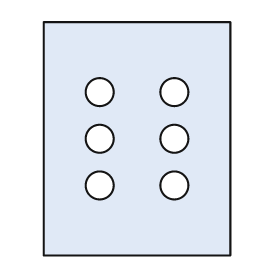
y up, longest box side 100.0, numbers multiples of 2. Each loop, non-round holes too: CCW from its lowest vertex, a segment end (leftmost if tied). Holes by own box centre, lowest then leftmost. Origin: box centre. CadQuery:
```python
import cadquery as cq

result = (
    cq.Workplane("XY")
    .moveTo(-40.0, -50.0)
    .lineTo(40.0, -50.0)
    .lineTo(40.0, 50.0)
    .lineTo(-40.0, 50.0)
    .close()
    .moveTo(-16.0, -20.0)
    .circle(6.0)
    .moveTo(16.0, -20.0)
    .circle(6.0)
    .moveTo(-16.0, 0.0)
    .circle(6.0)
    .moveTo(16.0, 0.0)
    .circle(6.0)
    .moveTo(-16.0, 20.0)
    .circle(6.0)
    .moveTo(16.0, 20.0)
    .circle(6.0)
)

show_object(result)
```